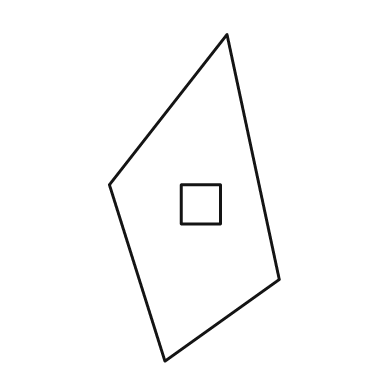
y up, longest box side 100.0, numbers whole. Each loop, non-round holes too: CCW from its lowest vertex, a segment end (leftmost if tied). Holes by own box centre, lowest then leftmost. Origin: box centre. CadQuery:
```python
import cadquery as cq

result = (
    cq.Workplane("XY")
    .moveTo(-9.0, -50.0)
    .lineTo(26.0, -25.0)
    .lineTo(10.0, 50.0)
    .lineTo(-26.0, 4.0)
    .close()
    .moveTo(-4.0, -8.0)
    .lineTo(8.0, -8.0)
    .lineTo(8.0, 4.0)
    .lineTo(-4.0, 4.0)
    .close()
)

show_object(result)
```